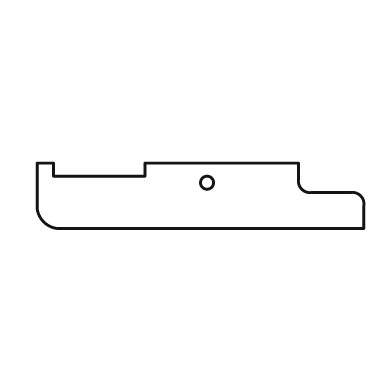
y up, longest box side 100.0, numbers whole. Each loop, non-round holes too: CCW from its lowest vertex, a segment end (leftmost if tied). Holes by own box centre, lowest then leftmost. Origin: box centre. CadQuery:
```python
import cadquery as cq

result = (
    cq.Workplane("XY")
    .moveTo(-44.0, -10.0)
    .lineTo(50.0, -10.0)
    .lineTo(50.0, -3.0)
    .threePointArc((49.0, 0.0), (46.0, 1.0))
    .lineTo(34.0, 1.0)
    .threePointArc((31.0, 2.0), (30.0, 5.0))
    .lineTo(30.0, 10.0)
    .lineTo(-17.0, 10.0)
    .lineTo(-17.0, 6.0)
    .lineTo(-45.0, 6.0)
    .lineTo(-45.0, 10.0)
    .lineTo(-50.0, 10.0)
    .lineTo(-50.0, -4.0)
    .threePointArc((-48.0, -8.0), (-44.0, -10.0))
    .close()
    .moveTo(2.0, 4.0)
    .circle(2.0)
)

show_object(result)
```